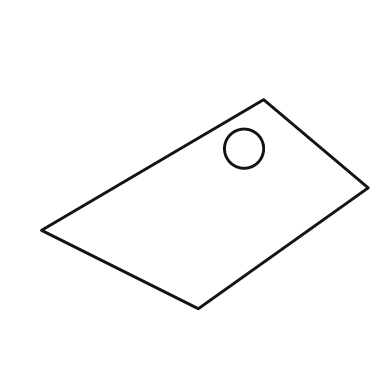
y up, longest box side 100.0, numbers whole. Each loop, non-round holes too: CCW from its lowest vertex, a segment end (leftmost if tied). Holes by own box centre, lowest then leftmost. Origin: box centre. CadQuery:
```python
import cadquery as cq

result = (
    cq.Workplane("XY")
    .moveTo(-2.0, -32.0)
    .lineTo(50.0, 5.0)
    .lineTo(18.0, 32.0)
    .lineTo(-50.0, -8.0)
    .close()
    .moveTo(12.0, 17.0)
    .circle(6.0)
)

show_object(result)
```